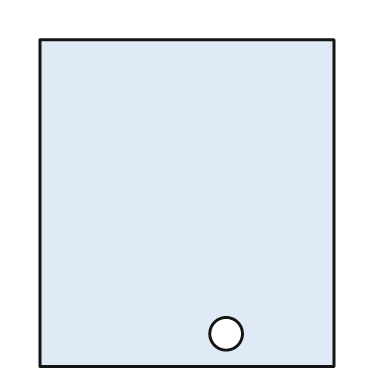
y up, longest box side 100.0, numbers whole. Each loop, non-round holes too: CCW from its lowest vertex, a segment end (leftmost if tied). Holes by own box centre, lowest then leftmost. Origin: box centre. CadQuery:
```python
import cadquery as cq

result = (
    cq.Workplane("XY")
    .moveTo(-45.0, -50.0)
    .lineTo(45.0, -50.0)
    .lineTo(45.0, 50.0)
    .lineTo(-45.0, 50.0)
    .close()
    .moveTo(12.0, -40.0)
    .circle(5.0)
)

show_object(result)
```